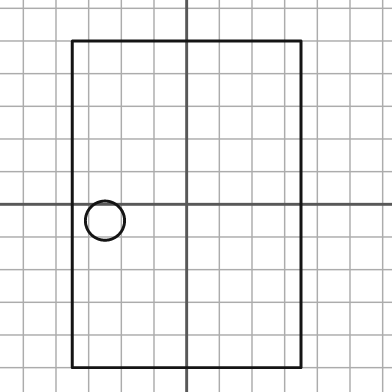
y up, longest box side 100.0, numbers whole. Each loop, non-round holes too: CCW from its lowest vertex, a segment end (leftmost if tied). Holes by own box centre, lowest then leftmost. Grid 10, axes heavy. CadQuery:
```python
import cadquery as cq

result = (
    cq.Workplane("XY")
    .moveTo(-35.0, -50.0)
    .lineTo(35.0, -50.0)
    .lineTo(35.0, 50.0)
    .lineTo(-35.0, 50.0)
    .close()
    .moveTo(-25.0, -5.0)
    .circle(6.0)
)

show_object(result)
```